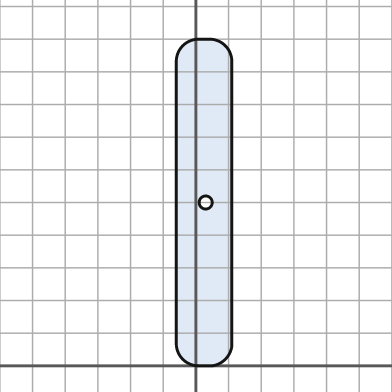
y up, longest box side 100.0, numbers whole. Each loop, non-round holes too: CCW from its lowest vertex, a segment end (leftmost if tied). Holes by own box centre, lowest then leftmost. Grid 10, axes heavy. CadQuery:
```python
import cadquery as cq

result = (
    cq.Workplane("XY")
    .moveTo(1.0, 0.0)
    .lineTo(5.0, 0.0)
    .threePointArc((9.0, 2.0), (11.0, 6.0))
    .lineTo(11.0, 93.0)
    .threePointArc((9.0, 98.0), (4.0, 100.0))
    .lineTo(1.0, 100.0)
    .threePointArc((-4.0, 98.0), (-6.0, 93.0))
    .lineTo(-6.0, 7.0)
    .threePointArc((-4.0, 2.0), (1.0, 0.0))
    .close()
    .moveTo(3.0, 50.0)
    .circle(2.0)
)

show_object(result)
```